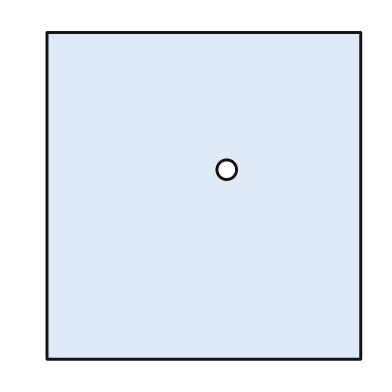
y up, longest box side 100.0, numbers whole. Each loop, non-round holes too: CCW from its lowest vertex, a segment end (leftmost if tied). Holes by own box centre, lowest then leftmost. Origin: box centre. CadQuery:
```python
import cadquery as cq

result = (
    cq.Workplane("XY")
    .moveTo(-48.0, -50.0)
    .lineTo(48.0, -50.0)
    .lineTo(48.0, 50.0)
    .lineTo(-48.0, 50.0)
    .close()
    .moveTo(7.0, 8.0)
    .circle(3.0)
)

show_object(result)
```